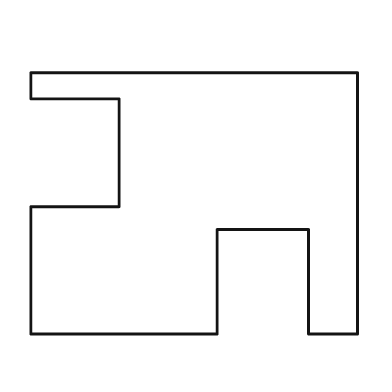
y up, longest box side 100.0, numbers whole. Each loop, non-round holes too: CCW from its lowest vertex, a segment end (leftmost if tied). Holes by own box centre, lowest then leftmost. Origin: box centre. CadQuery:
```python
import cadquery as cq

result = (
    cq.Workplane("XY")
    .moveTo(-50.0, -40.0)
    .lineTo(7.0, -40.0)
    .lineTo(7.0, -8.0)
    .lineTo(35.0, -8.0)
    .lineTo(35.0, -40.0)
    .lineTo(50.0, -40.0)
    .lineTo(50.0, 40.0)
    .lineTo(-50.0, 40.0)
    .lineTo(-50.0, 32.0)
    .lineTo(-23.0, 32.0)
    .lineTo(-23.0, -1.0)
    .lineTo(-50.0, -1.0)
    .close()
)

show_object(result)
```